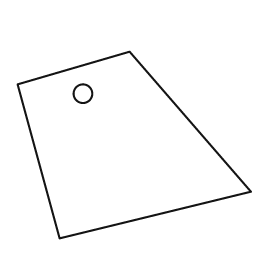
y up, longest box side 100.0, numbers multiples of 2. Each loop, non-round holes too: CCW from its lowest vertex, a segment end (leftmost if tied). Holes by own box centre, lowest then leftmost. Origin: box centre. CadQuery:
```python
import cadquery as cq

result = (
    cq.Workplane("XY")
    .moveTo(-32.0, -40.0)
    .lineTo(50.0, -20.0)
    .lineTo(-2.0, 40.0)
    .lineTo(-50.0, 26.0)
    .close()
    .moveTo(-22.0, 22.0)
    .circle(4.0)
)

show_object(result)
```